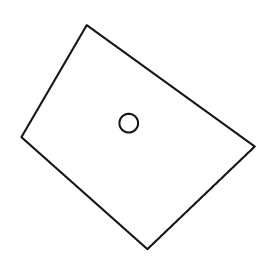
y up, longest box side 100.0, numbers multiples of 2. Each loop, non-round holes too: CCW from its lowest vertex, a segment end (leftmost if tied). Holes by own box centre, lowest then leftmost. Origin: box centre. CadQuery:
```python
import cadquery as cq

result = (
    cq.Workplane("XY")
    .moveTo(4.0, -48.0)
    .lineTo(50.0, -4.0)
    .lineTo(-22.0, 48.0)
    .lineTo(-50.0, 0.0)
    .close()
    .moveTo(-4.0, 6.0)
    .circle(4.0)
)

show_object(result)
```